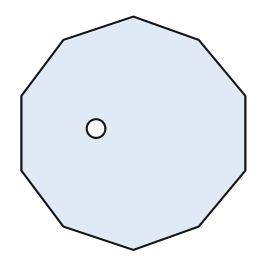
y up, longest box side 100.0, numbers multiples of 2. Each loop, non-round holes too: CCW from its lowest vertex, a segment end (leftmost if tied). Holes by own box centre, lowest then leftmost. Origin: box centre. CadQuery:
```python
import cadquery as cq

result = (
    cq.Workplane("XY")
    .moveTo(0.0, -50.0)
    .lineTo(28.0, -40.0)
    .lineTo(48.0, -16.0)
    .lineTo(48.0, 16.0)
    .lineTo(28.0, 40.0)
    .lineTo(0.0, 50.0)
    .lineTo(-30.0, 40.0)
    .lineTo(-48.0, 16.0)
    .lineTo(-48.0, -16.0)
    .lineTo(-30.0, -40.0)
    .close()
    .moveTo(-16.0, 2.0)
    .circle(4.0)
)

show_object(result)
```